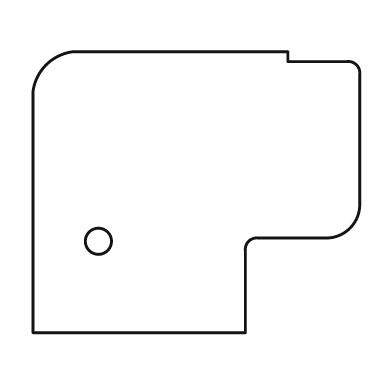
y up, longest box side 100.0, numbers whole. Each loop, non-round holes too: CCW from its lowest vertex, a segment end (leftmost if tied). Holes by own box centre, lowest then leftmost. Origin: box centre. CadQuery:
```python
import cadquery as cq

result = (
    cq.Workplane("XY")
    .moveTo(-50.0, -43.0)
    .lineTo(15.0, -43.0)
    .lineTo(15.0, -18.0)
    .threePointArc((16.0, -15.0), (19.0, -14.0))
    .lineTo(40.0, -14.0)
    .threePointArc((47.0, -11.0), (50.0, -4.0))
    .lineTo(50.0, 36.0)
    .threePointArc((49.0, 39.0), (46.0, 40.0))
    .lineTo(28.0, 40.0)
    .lineTo(28.0, 43.0)
    .lineTo(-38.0, 43.0)
    .threePointArc((-46.0, 39.0), (-50.0, 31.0))
    .close()
    .moveTo(-30.0, -15.0)
    .circle(4.0)
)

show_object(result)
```